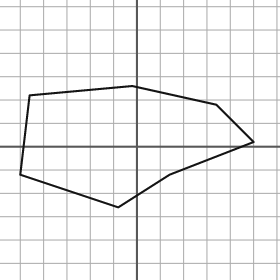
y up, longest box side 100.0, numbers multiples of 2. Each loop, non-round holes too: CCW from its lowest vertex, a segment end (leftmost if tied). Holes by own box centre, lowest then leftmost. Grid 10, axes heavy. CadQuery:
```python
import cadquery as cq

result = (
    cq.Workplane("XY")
    .moveTo(-8.0, -26.0)
    .lineTo(14.0, -12.0)
    .lineTo(50.0, 2.0)
    .lineTo(34.0, 18.0)
    .lineTo(-2.0, 26.0)
    .lineTo(-46.0, 22.0)
    .lineTo(-50.0, -12.0)
    .close()
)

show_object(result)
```